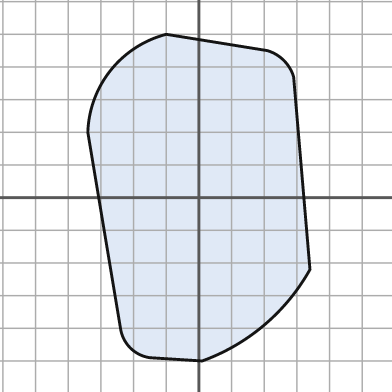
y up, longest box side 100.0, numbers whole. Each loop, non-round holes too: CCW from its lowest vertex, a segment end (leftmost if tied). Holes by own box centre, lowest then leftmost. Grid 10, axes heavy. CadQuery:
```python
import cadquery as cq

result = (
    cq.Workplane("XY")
    .moveTo(1.0, -50.0)
    .threePointArc((20.0, -39.0), (34.0, -22.0))
    .lineTo(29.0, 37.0)
    .threePointArc((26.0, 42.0), (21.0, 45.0))
    .lineTo(-10.0, 50.0)
    .threePointArc((-27.0, 39.0), (-34.0, 20.0))
    .lineTo(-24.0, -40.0)
    .threePointArc((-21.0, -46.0), (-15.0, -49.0))
    .close()
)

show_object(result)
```